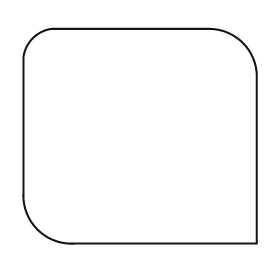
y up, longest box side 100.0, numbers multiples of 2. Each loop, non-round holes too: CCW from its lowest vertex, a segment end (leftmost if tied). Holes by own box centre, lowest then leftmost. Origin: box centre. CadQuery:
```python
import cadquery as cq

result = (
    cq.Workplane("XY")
    .moveTo(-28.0, -46.0)
    .lineTo(50.0, -46.0)
    .lineTo(50.0, 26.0)
    .threePointArc((44.0, 40.0), (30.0, 46.0))
    .lineTo(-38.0, 46.0)
    .threePointArc((-46.0, 42.0), (-50.0, 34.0))
    .lineTo(-50.0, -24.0)
    .threePointArc((-44.0, -40.0), (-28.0, -46.0))
    .close()
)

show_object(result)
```